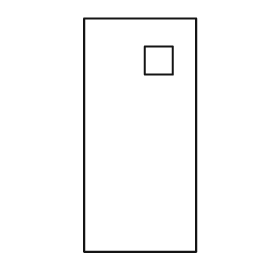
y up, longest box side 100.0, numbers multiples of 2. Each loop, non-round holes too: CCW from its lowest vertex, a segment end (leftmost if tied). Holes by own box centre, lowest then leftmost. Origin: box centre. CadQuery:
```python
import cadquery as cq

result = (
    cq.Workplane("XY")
    .moveTo(-24.0, -50.0)
    .lineTo(24.0, -50.0)
    .lineTo(24.0, 50.0)
    .lineTo(-24.0, 50.0)
    .close()
    .moveTo(2.0, 26.0)
    .lineTo(14.0, 26.0)
    .lineTo(14.0, 38.0)
    .lineTo(2.0, 38.0)
    .close()
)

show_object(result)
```